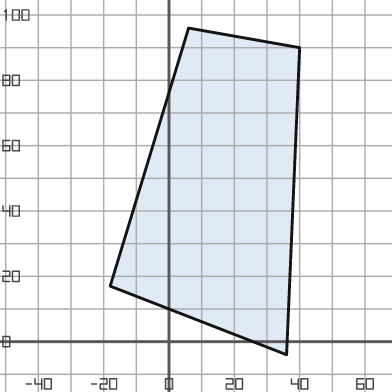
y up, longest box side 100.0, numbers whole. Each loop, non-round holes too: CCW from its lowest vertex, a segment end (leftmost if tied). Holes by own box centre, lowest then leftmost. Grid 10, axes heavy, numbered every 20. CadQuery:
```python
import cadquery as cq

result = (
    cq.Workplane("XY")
    .moveTo(36.0, -4.0)
    .lineTo(40.0, 90.0)
    .lineTo(6.0, 96.0)
    .lineTo(-18.0, 17.0)
    .close()
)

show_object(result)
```